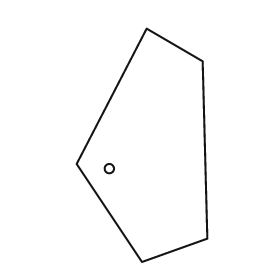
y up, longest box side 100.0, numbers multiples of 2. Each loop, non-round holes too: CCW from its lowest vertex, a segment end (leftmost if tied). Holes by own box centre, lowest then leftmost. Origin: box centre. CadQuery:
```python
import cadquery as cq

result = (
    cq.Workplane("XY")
    .moveTo(0.0, -50.0)
    .lineTo(28.0, -40.0)
    .lineTo(26.0, 36.0)
    .lineTo(2.0, 50.0)
    .lineTo(-28.0, -8.0)
    .close()
    .moveTo(-14.0, -10.0)
    .circle(2.0)
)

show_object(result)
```